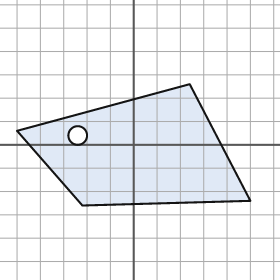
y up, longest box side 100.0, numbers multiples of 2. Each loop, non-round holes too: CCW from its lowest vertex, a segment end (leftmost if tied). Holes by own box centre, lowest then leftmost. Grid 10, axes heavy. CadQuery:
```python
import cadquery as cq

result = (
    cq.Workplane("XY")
    .moveTo(-22.0, -26.0)
    .lineTo(50.0, -24.0)
    .lineTo(24.0, 26.0)
    .lineTo(-50.0, 6.0)
    .close()
    .moveTo(-24.0, 4.0)
    .circle(4.0)
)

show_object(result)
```